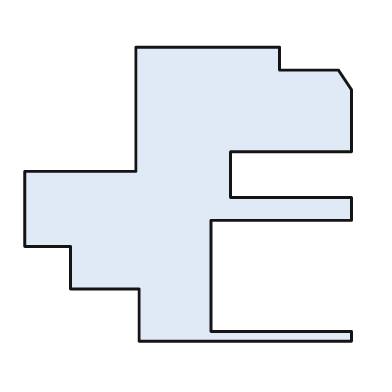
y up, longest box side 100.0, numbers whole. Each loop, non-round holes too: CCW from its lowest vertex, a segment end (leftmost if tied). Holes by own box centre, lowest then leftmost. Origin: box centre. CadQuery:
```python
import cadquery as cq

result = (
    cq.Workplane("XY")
    .moveTo(-15.0, -45.0)
    .lineTo(50.0, -45.0)
    .lineTo(50.0, -42.0)
    .lineTo(7.0, -42.0)
    .lineTo(7.0, -8.0)
    .lineTo(50.0, -8.0)
    .lineTo(50.0, -1.0)
    .lineTo(13.0, -1.0)
    .lineTo(13.0, 13.0)
    .lineTo(50.0, 13.0)
    .lineTo(50.0, 32.0)
    .lineTo(46.0, 38.0)
    .lineTo(28.0, 38.0)
    .lineTo(28.0, 45.0)
    .lineTo(-16.0, 45.0)
    .lineTo(-16.0, 7.0)
    .lineTo(-50.0, 7.0)
    .lineTo(-50.0, -16.0)
    .lineTo(-36.0, -16.0)
    .lineTo(-36.0, -29.0)
    .lineTo(-15.0, -29.0)
    .close()
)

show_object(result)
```